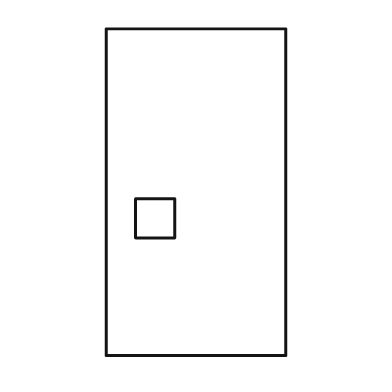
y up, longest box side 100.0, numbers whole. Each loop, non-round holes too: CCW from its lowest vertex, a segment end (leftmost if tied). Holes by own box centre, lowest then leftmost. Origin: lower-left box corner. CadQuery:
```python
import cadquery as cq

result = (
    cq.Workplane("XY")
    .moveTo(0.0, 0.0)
    .lineTo(55.0, 0.0)
    .lineTo(55.0, 100.0)
    .lineTo(0.0, 100.0)
    .close()
    .moveTo(9.0, 36.0)
    .lineTo(21.0, 36.0)
    .lineTo(21.0, 48.0)
    .lineTo(9.0, 48.0)
    .close()
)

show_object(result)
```